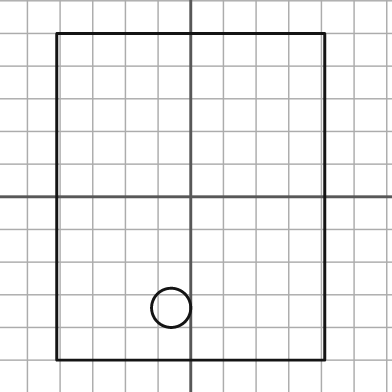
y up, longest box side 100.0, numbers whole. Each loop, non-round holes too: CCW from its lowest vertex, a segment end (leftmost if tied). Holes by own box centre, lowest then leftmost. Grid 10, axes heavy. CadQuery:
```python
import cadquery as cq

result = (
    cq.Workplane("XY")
    .moveTo(-41.0, -50.0)
    .lineTo(41.0, -50.0)
    .lineTo(41.0, 50.0)
    .lineTo(-41.0, 50.0)
    .close()
    .moveTo(-6.0, -34.0)
    .circle(6.0)
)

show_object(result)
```